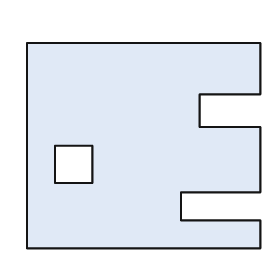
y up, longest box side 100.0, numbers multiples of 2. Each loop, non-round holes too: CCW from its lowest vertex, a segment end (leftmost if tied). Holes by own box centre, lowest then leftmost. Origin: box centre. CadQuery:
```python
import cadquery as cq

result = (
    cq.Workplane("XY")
    .moveTo(-50.0, -44.0)
    .lineTo(50.0, -44.0)
    .lineTo(50.0, -32.0)
    .lineTo(16.0, -32.0)
    .lineTo(16.0, -20.0)
    .lineTo(50.0, -20.0)
    .lineTo(50.0, 8.0)
    .lineTo(24.0, 8.0)
    .lineTo(24.0, 22.0)
    .lineTo(50.0, 22.0)
    .lineTo(50.0, 44.0)
    .lineTo(-50.0, 44.0)
    .close()
    .moveTo(-38.0, -16.0)
    .lineTo(-22.0, -16.0)
    .lineTo(-22.0, 0.0)
    .lineTo(-38.0, 0.0)
    .close()
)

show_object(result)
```